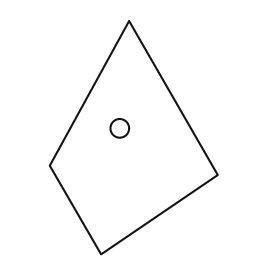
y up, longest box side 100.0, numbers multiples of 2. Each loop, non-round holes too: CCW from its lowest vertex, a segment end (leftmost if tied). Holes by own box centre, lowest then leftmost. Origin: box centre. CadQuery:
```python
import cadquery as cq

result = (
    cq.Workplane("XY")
    .moveTo(-14.0, -50.0)
    .lineTo(36.0, -16.0)
    .lineTo(-2.0, 50.0)
    .lineTo(-36.0, -12.0)
    .close()
    .moveTo(-6.0, 4.0)
    .circle(4.0)
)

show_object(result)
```